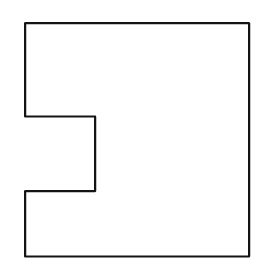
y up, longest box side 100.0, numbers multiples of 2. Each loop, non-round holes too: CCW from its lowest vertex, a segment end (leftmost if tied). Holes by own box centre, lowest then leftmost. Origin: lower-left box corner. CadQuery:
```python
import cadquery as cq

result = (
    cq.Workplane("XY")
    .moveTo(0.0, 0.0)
    .lineTo(96.0, 0.0)
    .lineTo(96.0, 100.0)
    .lineTo(0.0, 100.0)
    .lineTo(0.0, 60.0)
    .lineTo(30.0, 60.0)
    .lineTo(30.0, 28.0)
    .lineTo(0.0, 28.0)
    .close()
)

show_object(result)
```